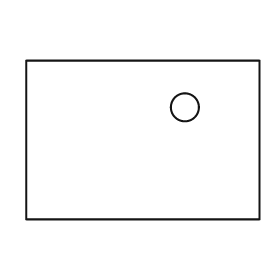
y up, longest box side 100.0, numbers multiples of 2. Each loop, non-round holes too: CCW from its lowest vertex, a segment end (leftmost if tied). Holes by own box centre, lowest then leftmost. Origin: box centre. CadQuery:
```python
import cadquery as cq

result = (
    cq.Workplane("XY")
    .moveTo(-50.0, -34.0)
    .lineTo(50.0, -34.0)
    .lineTo(50.0, 34.0)
    .lineTo(-50.0, 34.0)
    .close()
    .moveTo(18.0, 14.0)
    .circle(6.0)
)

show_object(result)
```